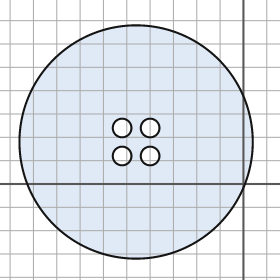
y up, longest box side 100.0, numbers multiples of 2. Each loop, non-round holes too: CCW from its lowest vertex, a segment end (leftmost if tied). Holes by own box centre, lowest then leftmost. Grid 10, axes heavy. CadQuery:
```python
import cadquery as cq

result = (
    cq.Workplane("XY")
    .moveTo(-46.0, 18.0)
    .circle(50.0)
    .moveTo(-52.0, 12.0)
    .circle(4.0)
    .moveTo(-40.0, 12.0)
    .circle(4.0)
    .moveTo(-52.0, 24.0)
    .circle(4.0)
    .moveTo(-40.0, 24.0)
    .circle(4.0)
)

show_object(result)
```